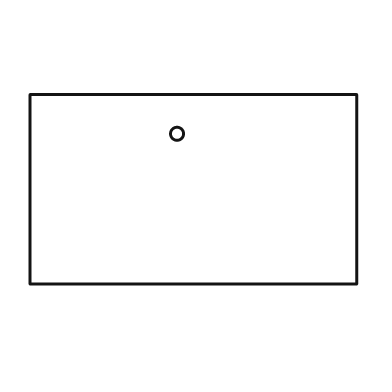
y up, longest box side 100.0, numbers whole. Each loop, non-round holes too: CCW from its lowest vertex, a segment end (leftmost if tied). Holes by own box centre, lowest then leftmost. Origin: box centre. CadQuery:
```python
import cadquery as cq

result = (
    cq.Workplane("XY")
    .moveTo(-50.0, -29.0)
    .lineTo(50.0, -29.0)
    .lineTo(50.0, 29.0)
    .lineTo(-50.0, 29.0)
    .close()
    .moveTo(-5.0, 17.0)
    .circle(2.0)
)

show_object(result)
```